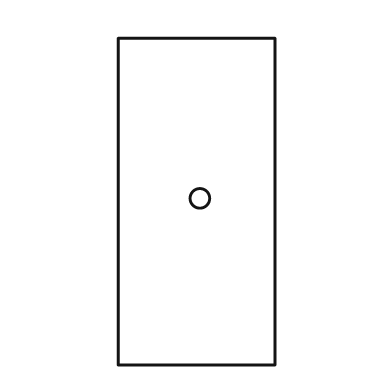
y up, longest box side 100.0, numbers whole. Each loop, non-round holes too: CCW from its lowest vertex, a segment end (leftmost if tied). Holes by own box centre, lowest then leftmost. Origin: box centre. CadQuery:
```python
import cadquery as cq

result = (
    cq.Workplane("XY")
    .moveTo(-24.0, -50.0)
    .lineTo(24.0, -50.0)
    .lineTo(24.0, 50.0)
    .lineTo(-24.0, 50.0)
    .close()
    .moveTo(1.0, 1.0)
    .circle(3.0)
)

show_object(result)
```